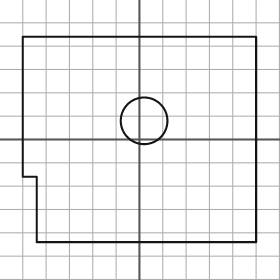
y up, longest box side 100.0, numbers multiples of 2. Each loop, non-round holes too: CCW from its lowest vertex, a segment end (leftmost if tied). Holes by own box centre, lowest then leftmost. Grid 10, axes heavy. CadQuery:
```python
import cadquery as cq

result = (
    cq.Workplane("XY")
    .moveTo(-44.0, -44.0)
    .lineTo(50.0, -44.0)
    .lineTo(50.0, 44.0)
    .lineTo(-50.0, 44.0)
    .lineTo(-50.0, -16.0)
    .lineTo(-44.0, -16.0)
    .close()
    .moveTo(2.0, 8.0)
    .circle(10.0)
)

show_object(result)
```